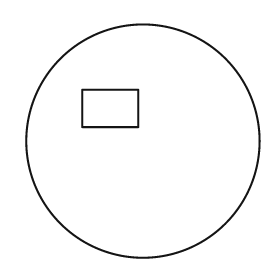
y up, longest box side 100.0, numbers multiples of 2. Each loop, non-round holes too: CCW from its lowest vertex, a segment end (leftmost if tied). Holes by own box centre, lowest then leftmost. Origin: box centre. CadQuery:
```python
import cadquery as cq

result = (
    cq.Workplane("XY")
    .moveTo(0.0, 0.0)
    .circle(50.0)
    .moveTo(-26.0, 6.0)
    .lineTo(-2.0, 6.0)
    .lineTo(-2.0, 22.0)
    .lineTo(-26.0, 22.0)
    .close()
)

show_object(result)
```